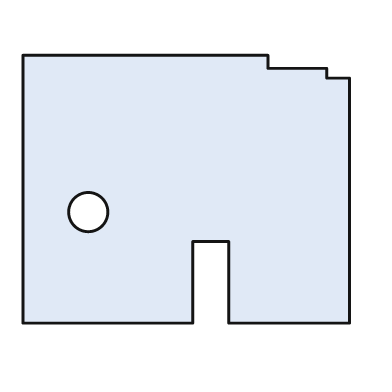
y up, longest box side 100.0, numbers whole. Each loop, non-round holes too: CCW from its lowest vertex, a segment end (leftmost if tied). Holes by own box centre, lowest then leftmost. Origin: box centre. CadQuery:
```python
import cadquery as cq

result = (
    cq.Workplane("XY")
    .moveTo(-50.0, -41.0)
    .lineTo(2.0, -41.0)
    .lineTo(2.0, -16.0)
    .lineTo(13.0, -16.0)
    .lineTo(13.0, -41.0)
    .lineTo(50.0, -41.0)
    .lineTo(50.0, 34.0)
    .lineTo(43.0, 34.0)
    .lineTo(43.0, 37.0)
    .lineTo(25.0, 37.0)
    .lineTo(25.0, 41.0)
    .lineTo(-50.0, 41.0)
    .close()
    .moveTo(-30.0, -7.0)
    .circle(6.0)
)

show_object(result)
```